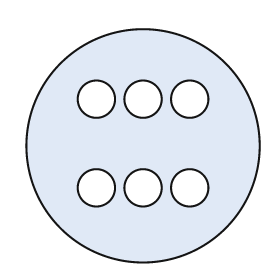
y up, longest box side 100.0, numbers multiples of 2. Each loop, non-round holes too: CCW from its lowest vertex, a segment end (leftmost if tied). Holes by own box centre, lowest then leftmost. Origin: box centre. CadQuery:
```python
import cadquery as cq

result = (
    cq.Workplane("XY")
    .moveTo(0.0, 0.0)
    .circle(50.0)
    .moveTo(-20.0, -18.0)
    .circle(8.0)
    .moveTo(0.0, -18.0)
    .circle(8.0)
    .moveTo(20.0, -18.0)
    .circle(8.0)
    .moveTo(-20.0, 20.0)
    .circle(8.0)
    .moveTo(0.0, 20.0)
    .circle(8.0)
    .moveTo(20.0, 20.0)
    .circle(8.0)
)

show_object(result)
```